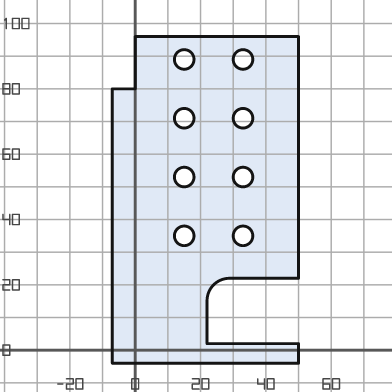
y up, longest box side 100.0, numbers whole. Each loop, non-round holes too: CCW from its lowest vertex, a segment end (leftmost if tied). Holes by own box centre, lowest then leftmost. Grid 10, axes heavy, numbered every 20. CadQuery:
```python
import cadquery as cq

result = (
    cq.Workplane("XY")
    .moveTo(-7.0, -4.0)
    .lineTo(50.0, -4.0)
    .lineTo(50.0, 2.0)
    .lineTo(22.0, 2.0)
    .lineTo(22.0, 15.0)
    .threePointArc((24.0, 20.0), (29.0, 22.0))
    .lineTo(50.0, 22.0)
    .lineTo(50.0, 96.0)
    .lineTo(0.0, 96.0)
    .lineTo(0.0, 80.0)
    .lineTo(-7.0, 80.0)
    .close()
    .moveTo(15.0, 35.0)
    .circle(3.0)
    .moveTo(33.0, 35.0)
    .circle(3.0)
    .moveTo(15.0, 53.0)
    .circle(3.0)
    .moveTo(33.0, 53.0)
    .circle(3.0)
    .moveTo(15.0, 71.0)
    .circle(3.0)
    .moveTo(33.0, 71.0)
    .circle(3.0)
    .moveTo(15.0, 89.0)
    .circle(3.0)
    .moveTo(33.0, 89.0)
    .circle(3.0)
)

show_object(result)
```